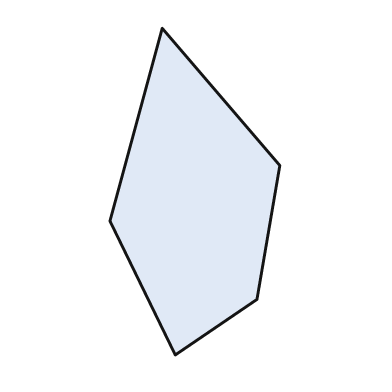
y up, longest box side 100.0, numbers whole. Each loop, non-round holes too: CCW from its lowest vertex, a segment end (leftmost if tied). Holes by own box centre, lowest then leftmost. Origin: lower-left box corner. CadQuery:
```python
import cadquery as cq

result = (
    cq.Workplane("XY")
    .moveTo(20.0, 0.0)
    .lineTo(45.0, 17.0)
    .lineTo(52.0, 58.0)
    .lineTo(16.0, 100.0)
    .lineTo(0.0, 41.0)
    .close()
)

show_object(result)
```